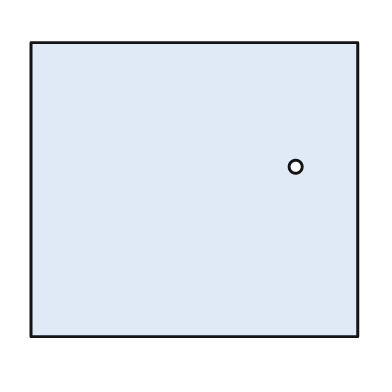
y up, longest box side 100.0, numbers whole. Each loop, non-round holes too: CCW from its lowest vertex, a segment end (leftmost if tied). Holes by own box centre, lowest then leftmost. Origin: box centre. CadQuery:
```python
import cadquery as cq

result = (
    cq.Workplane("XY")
    .moveTo(-50.0, -45.0)
    .lineTo(50.0, -45.0)
    .lineTo(50.0, 45.0)
    .lineTo(-50.0, 45.0)
    .close()
    .moveTo(31.0, 7.0)
    .circle(2.0)
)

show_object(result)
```